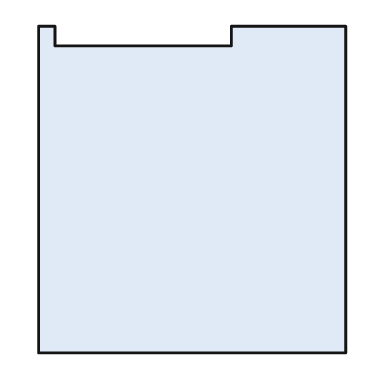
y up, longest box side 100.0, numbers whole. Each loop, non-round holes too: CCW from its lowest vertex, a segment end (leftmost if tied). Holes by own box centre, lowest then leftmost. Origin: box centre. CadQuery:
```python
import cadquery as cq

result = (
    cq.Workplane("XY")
    .moveTo(-47.0, -50.0)
    .lineTo(47.0, -50.0)
    .lineTo(47.0, 50.0)
    .lineTo(12.0, 50.0)
    .lineTo(12.0, 44.0)
    .lineTo(-42.0, 44.0)
    .lineTo(-42.0, 50.0)
    .lineTo(-47.0, 50.0)
    .close()
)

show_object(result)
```